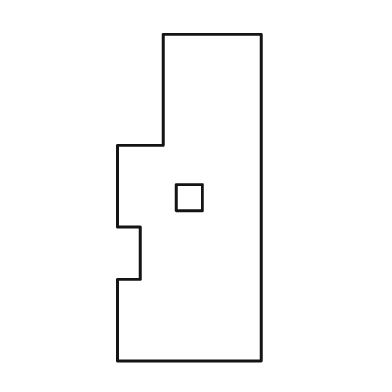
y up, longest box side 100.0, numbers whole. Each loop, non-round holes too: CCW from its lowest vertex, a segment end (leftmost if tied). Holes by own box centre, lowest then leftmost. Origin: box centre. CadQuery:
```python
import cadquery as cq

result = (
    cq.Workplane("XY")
    .moveTo(-22.0, -50.0)
    .lineTo(22.0, -50.0)
    .lineTo(22.0, 50.0)
    .lineTo(-8.0, 50.0)
    .lineTo(-8.0, 16.0)
    .lineTo(-22.0, 16.0)
    .lineTo(-22.0, -9.0)
    .lineTo(-15.0, -9.0)
    .lineTo(-15.0, -25.0)
    .lineTo(-22.0, -25.0)
    .close()
    .moveTo(-4.0, -4.0)
    .lineTo(4.0, -4.0)
    .lineTo(4.0, 4.0)
    .lineTo(-4.0, 4.0)
    .close()
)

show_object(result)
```